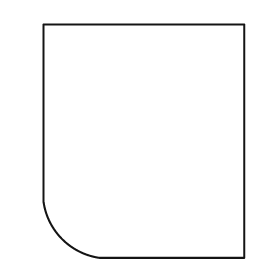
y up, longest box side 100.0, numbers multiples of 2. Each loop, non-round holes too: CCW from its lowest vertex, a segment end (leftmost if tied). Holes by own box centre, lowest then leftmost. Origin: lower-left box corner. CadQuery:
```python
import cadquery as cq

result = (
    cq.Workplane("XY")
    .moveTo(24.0, 0.0)
    .lineTo(86.0, 0.0)
    .lineTo(86.0, 100.0)
    .lineTo(0.0, 100.0)
    .lineTo(0.0, 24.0)
    .threePointArc((8.0, 8.0), (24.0, 0.0))
    .close()
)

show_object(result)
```